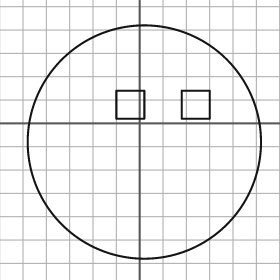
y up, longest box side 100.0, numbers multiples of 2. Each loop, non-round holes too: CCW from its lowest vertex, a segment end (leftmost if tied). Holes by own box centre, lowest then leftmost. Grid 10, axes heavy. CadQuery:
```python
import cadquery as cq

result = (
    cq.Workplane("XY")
    .moveTo(2.0, -8.0)
    .circle(50.0)
    .moveTo(-10.0, 2.0)
    .lineTo(2.0, 2.0)
    .lineTo(2.0, 14.0)
    .lineTo(-10.0, 14.0)
    .close()
    .moveTo(18.0, 2.0)
    .lineTo(30.0, 2.0)
    .lineTo(30.0, 14.0)
    .lineTo(18.0, 14.0)
    .close()
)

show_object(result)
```